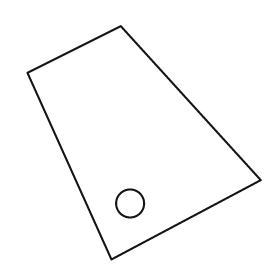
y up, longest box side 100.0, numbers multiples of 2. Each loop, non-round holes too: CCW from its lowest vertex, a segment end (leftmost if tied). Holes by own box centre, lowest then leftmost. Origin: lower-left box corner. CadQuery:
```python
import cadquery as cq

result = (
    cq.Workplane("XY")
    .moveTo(36.0, 0.0)
    .lineTo(100.0, 34.0)
    .lineTo(40.0, 100.0)
    .lineTo(0.0, 80.0)
    .close()
    .moveTo(44.0, 24.0)
    .circle(6.0)
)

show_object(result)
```